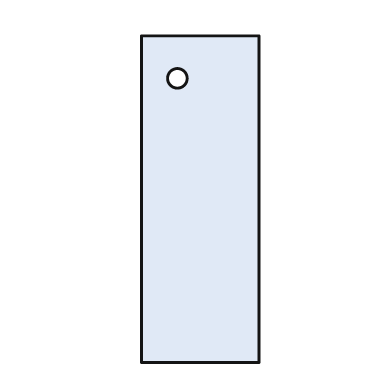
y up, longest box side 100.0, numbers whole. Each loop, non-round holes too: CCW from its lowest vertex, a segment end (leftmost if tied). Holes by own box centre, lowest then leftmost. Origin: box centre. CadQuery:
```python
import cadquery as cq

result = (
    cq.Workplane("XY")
    .moveTo(-18.0, -50.0)
    .lineTo(18.0, -50.0)
    .lineTo(18.0, 50.0)
    .lineTo(-18.0, 50.0)
    .close()
    .moveTo(-7.0, 37.0)
    .circle(3.0)
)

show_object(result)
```